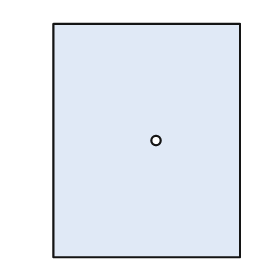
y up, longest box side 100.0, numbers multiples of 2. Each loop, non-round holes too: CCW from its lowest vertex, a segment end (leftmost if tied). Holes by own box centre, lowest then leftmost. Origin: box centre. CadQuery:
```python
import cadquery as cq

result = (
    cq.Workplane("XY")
    .moveTo(-40.0, -50.0)
    .lineTo(40.0, -50.0)
    .lineTo(40.0, 50.0)
    .lineTo(-40.0, 50.0)
    .close()
    .moveTo(4.0, 0.0)
    .circle(2.0)
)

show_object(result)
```